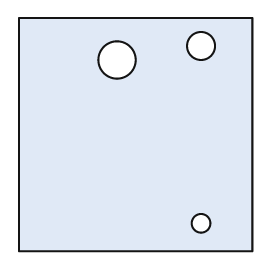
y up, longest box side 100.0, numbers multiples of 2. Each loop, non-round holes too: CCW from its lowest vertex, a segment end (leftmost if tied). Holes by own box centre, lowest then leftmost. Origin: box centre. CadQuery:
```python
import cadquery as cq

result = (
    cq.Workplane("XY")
    .moveTo(-50.0, -50.0)
    .lineTo(50.0, -50.0)
    .lineTo(50.0, 50.0)
    .lineTo(-50.0, 50.0)
    .close()
    .moveTo(28.0, -38.0)
    .circle(4.0)
    .moveTo(-8.0, 32.0)
    .circle(8.0)
    .moveTo(28.0, 38.0)
    .circle(6.0)
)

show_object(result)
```